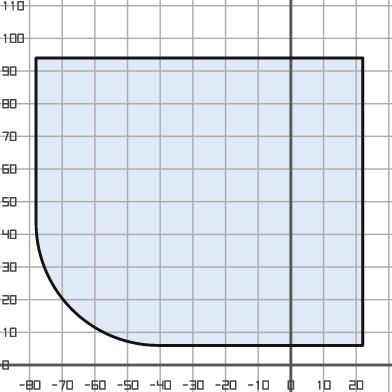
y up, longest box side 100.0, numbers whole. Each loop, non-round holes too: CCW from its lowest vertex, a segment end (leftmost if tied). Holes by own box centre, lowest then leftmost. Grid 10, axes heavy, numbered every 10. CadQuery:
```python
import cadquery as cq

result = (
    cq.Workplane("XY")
    .moveTo(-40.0, 6.0)
    .lineTo(22.0, 6.0)
    .lineTo(22.0, 94.0)
    .lineTo(-78.0, 94.0)
    .lineTo(-78.0, 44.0)
    .threePointArc((-67.0, 17.0), (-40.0, 6.0))
    .close()
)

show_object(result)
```